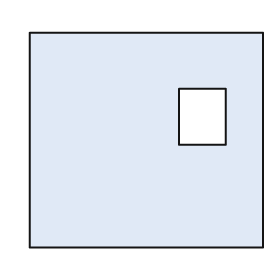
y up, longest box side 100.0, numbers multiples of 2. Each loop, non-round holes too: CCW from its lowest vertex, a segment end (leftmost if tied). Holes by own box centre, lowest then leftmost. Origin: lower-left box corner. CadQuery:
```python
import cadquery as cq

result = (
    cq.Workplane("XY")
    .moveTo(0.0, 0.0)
    .lineTo(100.0, 0.0)
    .lineTo(100.0, 92.0)
    .lineTo(0.0, 92.0)
    .close()
    .moveTo(64.0, 44.0)
    .lineTo(84.0, 44.0)
    .lineTo(84.0, 68.0)
    .lineTo(64.0, 68.0)
    .close()
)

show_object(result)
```